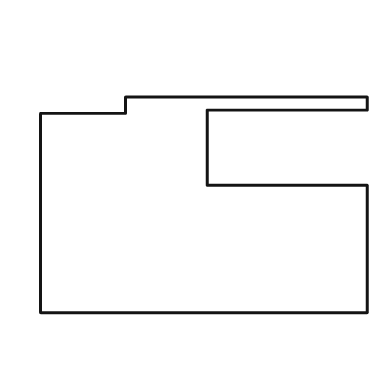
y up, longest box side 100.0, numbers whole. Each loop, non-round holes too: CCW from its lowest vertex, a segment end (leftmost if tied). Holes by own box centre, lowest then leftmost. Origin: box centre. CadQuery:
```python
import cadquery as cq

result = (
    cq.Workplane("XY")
    .moveTo(-50.0, -33.0)
    .lineTo(50.0, -33.0)
    .lineTo(50.0, 6.0)
    .lineTo(1.0, 6.0)
    .lineTo(1.0, 29.0)
    .lineTo(50.0, 29.0)
    .lineTo(50.0, 33.0)
    .lineTo(-24.0, 33.0)
    .lineTo(-24.0, 28.0)
    .lineTo(-50.0, 28.0)
    .close()
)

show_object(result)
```